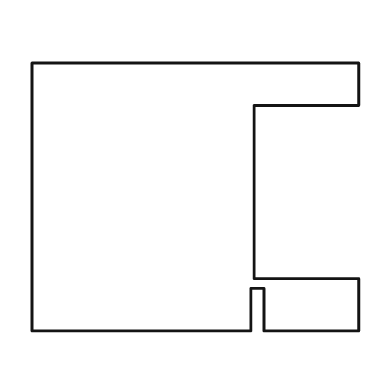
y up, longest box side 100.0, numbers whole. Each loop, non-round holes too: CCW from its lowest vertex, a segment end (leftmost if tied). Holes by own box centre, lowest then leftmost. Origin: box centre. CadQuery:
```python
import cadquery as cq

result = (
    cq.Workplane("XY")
    .moveTo(-50.0, -41.0)
    .lineTo(17.0, -41.0)
    .lineTo(17.0, -28.0)
    .lineTo(21.0, -28.0)
    .lineTo(21.0, -41.0)
    .lineTo(50.0, -41.0)
    .lineTo(50.0, -25.0)
    .lineTo(18.0, -25.0)
    .lineTo(18.0, 28.0)
    .lineTo(50.0, 28.0)
    .lineTo(50.0, 41.0)
    .lineTo(-50.0, 41.0)
    .close()
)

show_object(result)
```